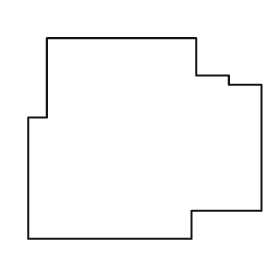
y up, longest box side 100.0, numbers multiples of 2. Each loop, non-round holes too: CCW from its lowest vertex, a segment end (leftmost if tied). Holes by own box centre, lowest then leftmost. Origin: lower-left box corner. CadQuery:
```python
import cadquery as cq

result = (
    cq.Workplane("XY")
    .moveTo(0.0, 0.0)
    .lineTo(70.0, 0.0)
    .lineTo(70.0, 12.0)
    .lineTo(100.0, 12.0)
    .lineTo(100.0, 66.0)
    .lineTo(86.0, 66.0)
    .lineTo(86.0, 70.0)
    .lineTo(72.0, 70.0)
    .lineTo(72.0, 86.0)
    .lineTo(8.0, 86.0)
    .lineTo(8.0, 52.0)
    .lineTo(0.0, 52.0)
    .close()
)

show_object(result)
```